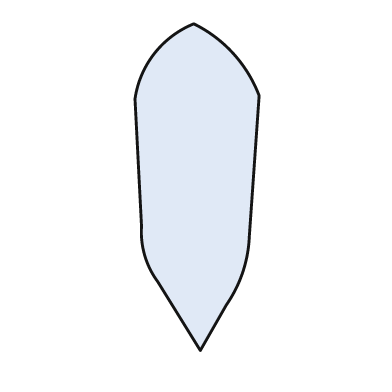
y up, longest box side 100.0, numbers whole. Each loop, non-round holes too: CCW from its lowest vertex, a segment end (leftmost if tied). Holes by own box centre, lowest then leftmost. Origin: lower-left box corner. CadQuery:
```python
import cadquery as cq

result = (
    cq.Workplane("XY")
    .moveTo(20.0, 0.0)
    .lineTo(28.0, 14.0)
    .threePointArc((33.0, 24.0), (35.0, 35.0))
    .lineTo(38.0, 78.0)
    .threePointArc((30.0, 91.0), (18.0, 100.0))
    .threePointArc((6.0, 91.0), (0.0, 77.0))
    .lineTo(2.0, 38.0)
    .threePointArc((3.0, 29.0), (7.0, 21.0))
    .close()
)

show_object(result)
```